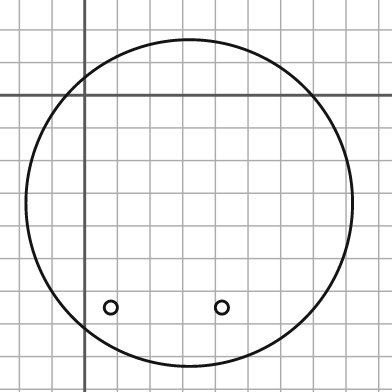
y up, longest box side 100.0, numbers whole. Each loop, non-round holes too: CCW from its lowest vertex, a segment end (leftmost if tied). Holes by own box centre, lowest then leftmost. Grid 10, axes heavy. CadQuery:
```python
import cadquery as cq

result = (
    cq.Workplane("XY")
    .moveTo(32.0, -33.0)
    .circle(50.0)
    .moveTo(8.0, -65.0)
    .circle(2.0)
    .moveTo(42.0, -65.0)
    .circle(2.0)
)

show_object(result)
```